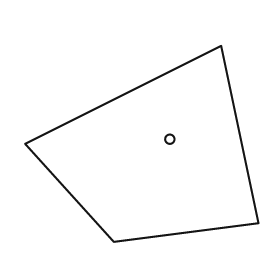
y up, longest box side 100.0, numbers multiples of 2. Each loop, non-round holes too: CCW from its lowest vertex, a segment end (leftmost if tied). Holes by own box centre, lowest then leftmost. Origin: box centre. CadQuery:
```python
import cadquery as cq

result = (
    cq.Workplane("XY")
    .moveTo(-12.0, -42.0)
    .lineTo(50.0, -34.0)
    .lineTo(34.0, 42.0)
    .lineTo(-50.0, 0.0)
    .close()
    .moveTo(12.0, 2.0)
    .circle(2.0)
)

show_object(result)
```